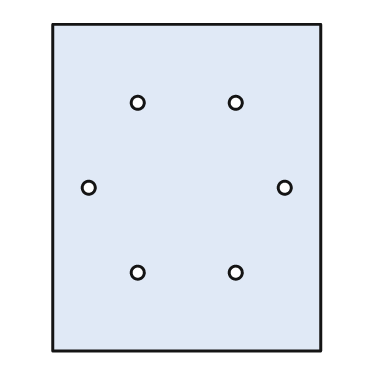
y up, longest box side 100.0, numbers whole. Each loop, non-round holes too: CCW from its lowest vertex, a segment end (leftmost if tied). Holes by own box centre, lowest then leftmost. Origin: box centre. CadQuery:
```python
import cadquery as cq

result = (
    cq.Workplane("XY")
    .moveTo(-41.0, -50.0)
    .lineTo(41.0, -50.0)
    .lineTo(41.0, 50.0)
    .lineTo(-41.0, 50.0)
    .close()
    .moveTo(-15.0, -26.0)
    .circle(2.0)
    .moveTo(15.0, -26.0)
    .circle(2.0)
    .moveTo(-30.0, 0.0)
    .circle(2.0)
    .moveTo(30.0, 0.0)
    .circle(2.0)
    .moveTo(-15.0, 26.0)
    .circle(2.0)
    .moveTo(15.0, 26.0)
    .circle(2.0)
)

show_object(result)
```